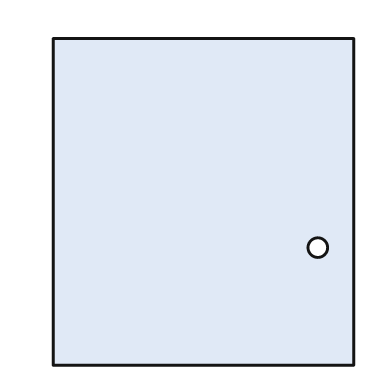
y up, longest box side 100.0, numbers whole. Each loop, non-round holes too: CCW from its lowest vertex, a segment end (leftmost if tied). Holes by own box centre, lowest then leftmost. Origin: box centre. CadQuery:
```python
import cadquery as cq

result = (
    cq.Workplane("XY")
    .moveTo(-46.0, -50.0)
    .lineTo(46.0, -50.0)
    .lineTo(46.0, 50.0)
    .lineTo(-46.0, 50.0)
    .close()
    .moveTo(35.0, -14.0)
    .circle(3.0)
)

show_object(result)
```